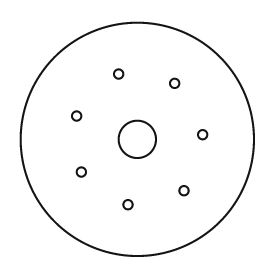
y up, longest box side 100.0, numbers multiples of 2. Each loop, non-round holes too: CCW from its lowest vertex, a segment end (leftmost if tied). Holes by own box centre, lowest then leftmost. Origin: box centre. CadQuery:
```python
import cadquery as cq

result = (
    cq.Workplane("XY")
    .moveTo(0.0, 0.0)
    .circle(50.0)
    .moveTo(-4.0, -28.0)
    .circle(2.0)
    .moveTo(20.0, -22.0)
    .circle(2.0)
    .moveTo(-24.0, -14.0)
    .circle(2.0)
    .moveTo(0.0, 0.0)
    .circle(8.0)
    .moveTo(28.0, 2.0)
    .circle(2.0)
    .moveTo(-26.0, 10.0)
    .circle(2.0)
    .moveTo(16.0, 24.0)
    .circle(2.0)
    .moveTo(-8.0, 28.0)
    .circle(2.0)
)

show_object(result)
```